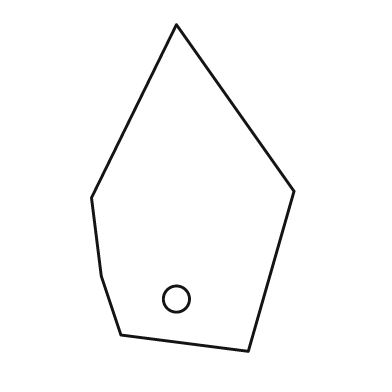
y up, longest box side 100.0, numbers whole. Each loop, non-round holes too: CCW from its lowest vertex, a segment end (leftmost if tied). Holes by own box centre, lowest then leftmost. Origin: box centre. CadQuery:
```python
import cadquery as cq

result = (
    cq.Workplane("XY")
    .moveTo(17.0, -50.0)
    .lineTo(31.0, -1.0)
    .lineTo(-5.0, 50.0)
    .lineTo(-31.0, -3.0)
    .lineTo(-28.0, -27.0)
    .lineTo(-22.0, -45.0)
    .close()
    .moveTo(-5.0, -34.0)
    .circle(4.0)
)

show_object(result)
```